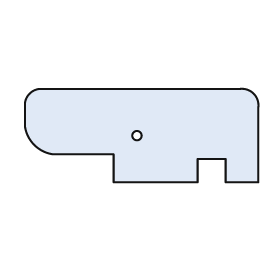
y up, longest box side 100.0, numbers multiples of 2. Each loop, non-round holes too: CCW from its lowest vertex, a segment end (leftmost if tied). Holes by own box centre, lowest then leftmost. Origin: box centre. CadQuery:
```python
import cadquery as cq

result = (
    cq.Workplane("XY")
    .moveTo(-12.0, -20.0)
    .lineTo(24.0, -20.0)
    .lineTo(24.0, -10.0)
    .lineTo(36.0, -10.0)
    .lineTo(36.0, -20.0)
    .lineTo(50.0, -20.0)
    .lineTo(50.0, 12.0)
    .threePointArc((48.0, 18.0), (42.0, 20.0))
    .lineTo(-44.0, 20.0)
    .threePointArc((-48.0, 18.0), (-50.0, 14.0))
    .lineTo(-50.0, 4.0)
    .threePointArc((-46.0, -4.0), (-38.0, -8.0))
    .lineTo(-12.0, -8.0)
    .close()
    .moveTo(-2.0, 0.0)
    .circle(2.0)
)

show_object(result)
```